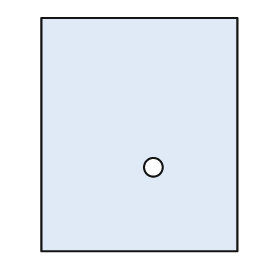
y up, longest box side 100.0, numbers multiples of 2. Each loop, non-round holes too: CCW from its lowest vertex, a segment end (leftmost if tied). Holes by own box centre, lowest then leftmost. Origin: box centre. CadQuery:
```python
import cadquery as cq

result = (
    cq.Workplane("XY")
    .moveTo(-42.0, -50.0)
    .lineTo(42.0, -50.0)
    .lineTo(42.0, 50.0)
    .lineTo(-42.0, 50.0)
    .close()
    .moveTo(6.0, -14.0)
    .circle(4.0)
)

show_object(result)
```